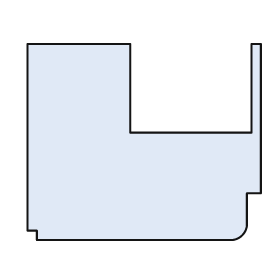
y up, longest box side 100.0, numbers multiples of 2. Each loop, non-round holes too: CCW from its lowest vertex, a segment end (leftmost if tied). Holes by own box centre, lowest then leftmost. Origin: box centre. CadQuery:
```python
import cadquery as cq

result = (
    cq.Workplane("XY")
    .moveTo(-46.0, -42.0)
    .lineTo(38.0, -42.0)
    .threePointArc((42.0, -40.0), (44.0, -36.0))
    .lineTo(44.0, -22.0)
    .lineTo(50.0, -22.0)
    .lineTo(50.0, 42.0)
    .lineTo(46.0, 42.0)
    .lineTo(46.0, 4.0)
    .lineTo(-6.0, 4.0)
    .lineTo(-6.0, 42.0)
    .lineTo(-50.0, 42.0)
    .lineTo(-50.0, -38.0)
    .lineTo(-46.0, -38.0)
    .close()
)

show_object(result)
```